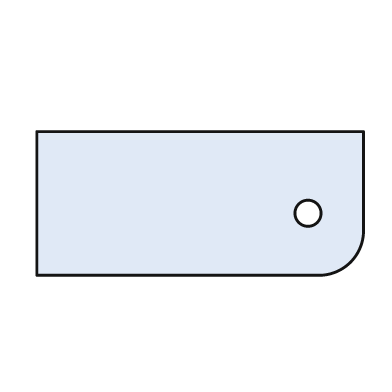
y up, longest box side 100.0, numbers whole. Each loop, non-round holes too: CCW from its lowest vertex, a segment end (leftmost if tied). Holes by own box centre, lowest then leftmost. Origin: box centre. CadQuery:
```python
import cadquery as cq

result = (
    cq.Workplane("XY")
    .moveTo(-50.0, -22.0)
    .lineTo(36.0, -22.0)
    .threePointArc((46.0, -18.0), (50.0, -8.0))
    .lineTo(50.0, 22.0)
    .lineTo(-50.0, 22.0)
    .close()
    .moveTo(33.0, -3.0)
    .circle(4.0)
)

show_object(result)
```